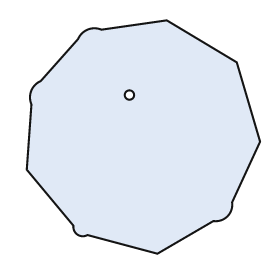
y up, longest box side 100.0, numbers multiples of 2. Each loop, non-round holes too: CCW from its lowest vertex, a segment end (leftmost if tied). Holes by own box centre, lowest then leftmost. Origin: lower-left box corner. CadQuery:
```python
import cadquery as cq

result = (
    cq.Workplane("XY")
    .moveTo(56.0, 0.0)
    .lineTo(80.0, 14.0)
    .threePointArc((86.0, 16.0), (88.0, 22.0))
    .lineTo(100.0, 48.0)
    .lineTo(90.0, 82.0)
    .lineTo(60.0, 100.0)
    .lineTo(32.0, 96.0)
    .threePointArc((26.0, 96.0), (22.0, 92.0))
    .lineTo(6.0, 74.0)
    .threePointArc((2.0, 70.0), (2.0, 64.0))
    .lineTo(0.0, 36.0)
    .lineTo(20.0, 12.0)
    .threePointArc((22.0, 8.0), (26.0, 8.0))
    .close()
    .moveTo(44.0, 68.0)
    .circle(2.0)
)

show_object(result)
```